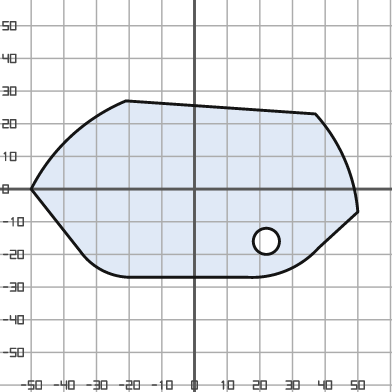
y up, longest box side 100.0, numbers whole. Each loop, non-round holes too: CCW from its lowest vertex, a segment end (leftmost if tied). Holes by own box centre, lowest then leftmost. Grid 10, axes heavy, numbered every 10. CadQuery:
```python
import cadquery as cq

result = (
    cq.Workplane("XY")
    .moveTo(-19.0, -27.0)
    .lineTo(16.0, -27.0)
    .threePointArc((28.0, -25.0), (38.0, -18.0))
    .lineTo(50.0, -7.0)
    .threePointArc((46.0, 9.0), (37.0, 23.0))
    .lineTo(-21.0, 27.0)
    .threePointArc((-38.0, 16.0), (-50.0, 0.0))
    .lineTo(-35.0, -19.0)
    .threePointArc((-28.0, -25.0), (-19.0, -27.0))
    .close()
    .moveTo(22.0, -16.0)
    .circle(4.0)
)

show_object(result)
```